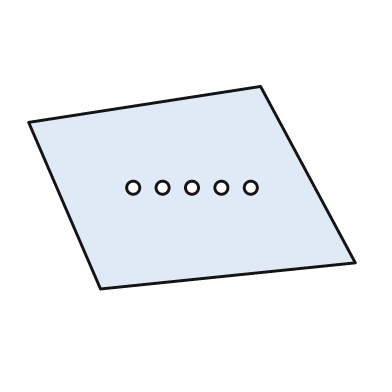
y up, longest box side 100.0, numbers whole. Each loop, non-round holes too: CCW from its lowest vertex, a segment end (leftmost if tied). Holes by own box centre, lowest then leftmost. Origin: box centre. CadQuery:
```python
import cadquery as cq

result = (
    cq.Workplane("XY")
    .moveTo(-28.0, -31.0)
    .lineTo(50.0, -23.0)
    .lineTo(21.0, 31.0)
    .lineTo(-50.0, 20.0)
    .close()
    .moveTo(-18.0, 0.0)
    .circle(2.0)
    .moveTo(-9.0, 0.0)
    .circle(2.0)
    .moveTo(0.0, 0.0)
    .circle(2.0)
    .moveTo(9.0, 0.0)
    .circle(2.0)
    .moveTo(18.0, 0.0)
    .circle(2.0)
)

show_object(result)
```